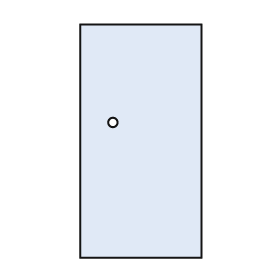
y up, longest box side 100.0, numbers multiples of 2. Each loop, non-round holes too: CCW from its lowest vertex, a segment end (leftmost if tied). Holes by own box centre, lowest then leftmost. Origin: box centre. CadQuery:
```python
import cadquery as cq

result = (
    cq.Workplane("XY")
    .moveTo(-26.0, -50.0)
    .lineTo(26.0, -50.0)
    .lineTo(26.0, 50.0)
    .lineTo(-26.0, 50.0)
    .close()
    .moveTo(-12.0, 8.0)
    .circle(2.0)
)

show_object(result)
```